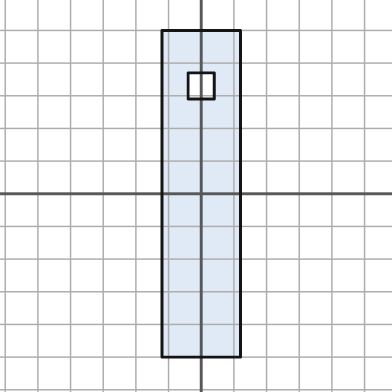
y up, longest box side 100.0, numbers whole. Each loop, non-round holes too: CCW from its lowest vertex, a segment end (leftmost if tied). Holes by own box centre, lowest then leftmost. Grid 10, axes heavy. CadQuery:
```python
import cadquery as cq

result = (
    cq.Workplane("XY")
    .moveTo(-12.0, -50.0)
    .lineTo(12.0, -50.0)
    .lineTo(12.0, 50.0)
    .lineTo(-12.0, 50.0)
    .close()
    .moveTo(-4.0, 29.0)
    .lineTo(4.0, 29.0)
    .lineTo(4.0, 37.0)
    .lineTo(-4.0, 37.0)
    .close()
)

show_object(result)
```